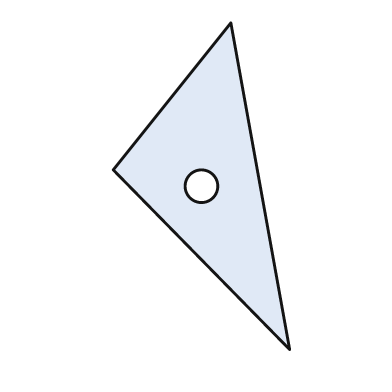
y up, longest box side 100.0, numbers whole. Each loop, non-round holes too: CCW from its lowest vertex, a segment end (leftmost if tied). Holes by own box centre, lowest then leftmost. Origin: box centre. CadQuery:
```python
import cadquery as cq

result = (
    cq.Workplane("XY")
    .moveTo(27.0, -50.0)
    .lineTo(9.0, 50.0)
    .lineTo(-27.0, 5.0)
    .close()
    .moveTo(0.0, 0.0)
    .circle(5.0)
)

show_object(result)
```